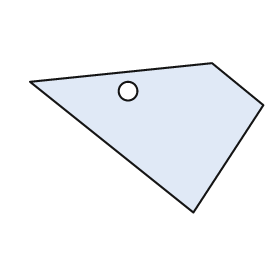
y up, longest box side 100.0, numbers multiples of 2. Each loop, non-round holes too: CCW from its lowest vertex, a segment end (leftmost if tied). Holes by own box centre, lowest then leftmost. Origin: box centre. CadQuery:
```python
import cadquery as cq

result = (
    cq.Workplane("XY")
    .moveTo(20.0, -32.0)
    .lineTo(50.0, 14.0)
    .lineTo(28.0, 32.0)
    .lineTo(-50.0, 24.0)
    .close()
    .moveTo(-8.0, 20.0)
    .circle(4.0)
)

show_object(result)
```